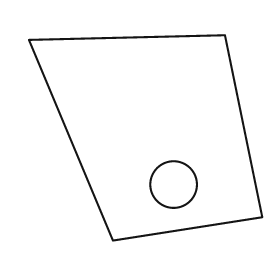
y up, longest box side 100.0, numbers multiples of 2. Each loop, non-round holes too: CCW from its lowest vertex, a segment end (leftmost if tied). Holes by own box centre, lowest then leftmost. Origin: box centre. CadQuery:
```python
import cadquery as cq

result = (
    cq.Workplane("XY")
    .moveTo(-14.0, -44.0)
    .lineTo(50.0, -34.0)
    .lineTo(34.0, 44.0)
    .lineTo(-50.0, 42.0)
    .close()
    .moveTo(12.0, -20.0)
    .circle(10.0)
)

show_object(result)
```